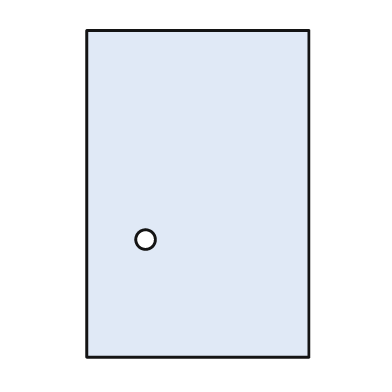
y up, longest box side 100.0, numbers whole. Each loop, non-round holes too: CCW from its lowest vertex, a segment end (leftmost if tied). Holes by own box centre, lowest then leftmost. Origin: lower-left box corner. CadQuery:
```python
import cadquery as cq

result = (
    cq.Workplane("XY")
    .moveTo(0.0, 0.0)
    .lineTo(68.0, 0.0)
    .lineTo(68.0, 100.0)
    .lineTo(0.0, 100.0)
    .close()
    .moveTo(18.0, 36.0)
    .circle(3.0)
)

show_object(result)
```